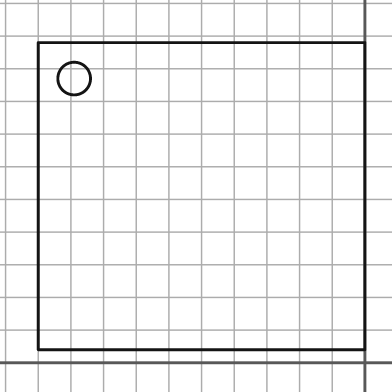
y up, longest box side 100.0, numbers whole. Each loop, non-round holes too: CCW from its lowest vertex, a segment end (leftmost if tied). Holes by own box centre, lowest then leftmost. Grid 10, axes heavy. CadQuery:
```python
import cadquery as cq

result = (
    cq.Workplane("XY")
    .moveTo(-100.0, 4.0)
    .lineTo(0.0, 4.0)
    .lineTo(0.0, 98.0)
    .lineTo(-100.0, 98.0)
    .close()
    .moveTo(-89.0, 87.0)
    .circle(5.0)
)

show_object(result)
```